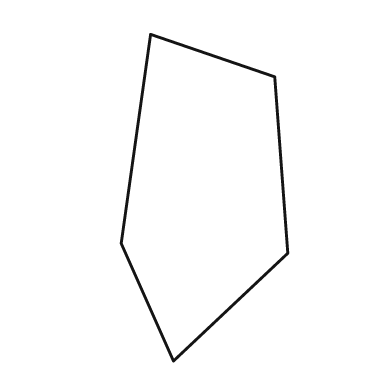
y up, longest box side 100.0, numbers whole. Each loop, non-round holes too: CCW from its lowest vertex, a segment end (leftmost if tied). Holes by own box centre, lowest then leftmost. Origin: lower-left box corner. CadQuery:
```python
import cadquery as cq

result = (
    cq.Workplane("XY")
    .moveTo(16.0, 0.0)
    .lineTo(51.0, 33.0)
    .lineTo(47.0, 87.0)
    .lineTo(9.0, 100.0)
    .lineTo(0.0, 36.0)
    .close()
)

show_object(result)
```